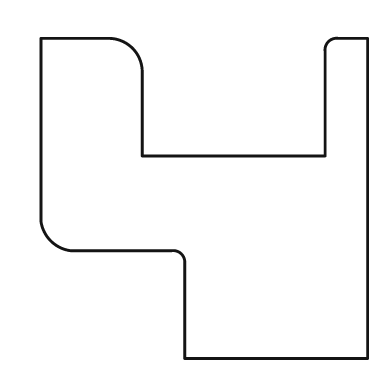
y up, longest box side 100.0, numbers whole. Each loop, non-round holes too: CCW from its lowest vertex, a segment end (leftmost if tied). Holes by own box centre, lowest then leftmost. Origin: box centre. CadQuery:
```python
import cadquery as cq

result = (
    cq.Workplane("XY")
    .moveTo(-6.0, -49.0)
    .lineTo(50.0, -49.0)
    .lineTo(50.0, 49.0)
    .lineTo(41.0, 49.0)
    .threePointArc((38.0, 48.0), (37.0, 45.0))
    .lineTo(37.0, 13.0)
    .lineTo(-19.0, 13.0)
    .lineTo(-19.0, 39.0)
    .threePointArc((-22.0, 46.0), (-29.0, 49.0))
    .lineTo(-50.0, 49.0)
    .lineTo(-50.0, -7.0)
    .threePointArc((-47.0, -13.0), (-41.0, -16.0))
    .lineTo(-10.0, -16.0)
    .threePointArc((-7.0, -17.0), (-6.0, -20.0))
    .close()
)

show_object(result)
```